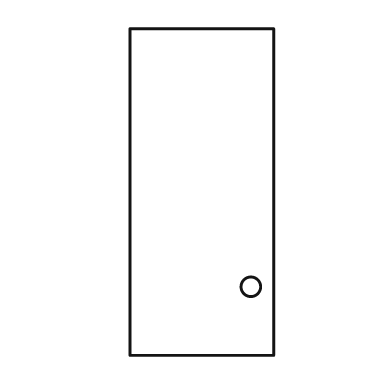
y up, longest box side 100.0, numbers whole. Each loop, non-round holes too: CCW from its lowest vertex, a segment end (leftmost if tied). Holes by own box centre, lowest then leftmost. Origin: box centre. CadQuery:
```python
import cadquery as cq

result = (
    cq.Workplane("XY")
    .moveTo(-22.0, -50.0)
    .lineTo(22.0, -50.0)
    .lineTo(22.0, 50.0)
    .lineTo(-22.0, 50.0)
    .close()
    .moveTo(15.0, -29.0)
    .circle(3.0)
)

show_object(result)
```